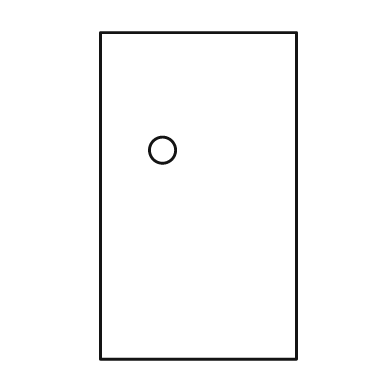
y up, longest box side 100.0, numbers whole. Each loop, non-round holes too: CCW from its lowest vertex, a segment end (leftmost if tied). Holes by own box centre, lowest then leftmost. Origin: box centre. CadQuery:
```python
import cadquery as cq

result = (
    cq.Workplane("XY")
    .moveTo(-30.0, -50.0)
    .lineTo(30.0, -50.0)
    .lineTo(30.0, 50.0)
    .lineTo(-30.0, 50.0)
    .close()
    .moveTo(-11.0, 14.0)
    .circle(4.0)
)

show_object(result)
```